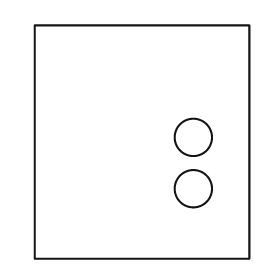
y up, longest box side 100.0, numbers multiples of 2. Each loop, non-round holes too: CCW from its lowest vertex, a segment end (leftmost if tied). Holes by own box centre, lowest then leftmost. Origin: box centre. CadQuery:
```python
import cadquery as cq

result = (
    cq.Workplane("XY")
    .moveTo(-46.0, -50.0)
    .lineTo(46.0, -50.0)
    .lineTo(46.0, 50.0)
    .lineTo(-46.0, 50.0)
    .close()
    .moveTo(22.0, -20.0)
    .circle(8.0)
    .moveTo(22.0, 2.0)
    .circle(8.0)
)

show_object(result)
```